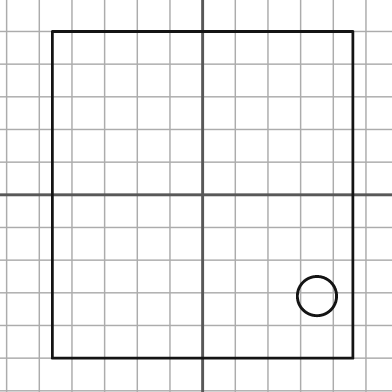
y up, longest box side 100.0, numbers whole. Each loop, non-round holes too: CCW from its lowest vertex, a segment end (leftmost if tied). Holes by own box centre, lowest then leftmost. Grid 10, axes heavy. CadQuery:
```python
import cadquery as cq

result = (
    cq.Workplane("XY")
    .moveTo(-46.0, -50.0)
    .lineTo(46.0, -50.0)
    .lineTo(46.0, 50.0)
    .lineTo(-46.0, 50.0)
    .close()
    .moveTo(35.0, -31.0)
    .circle(6.0)
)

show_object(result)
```